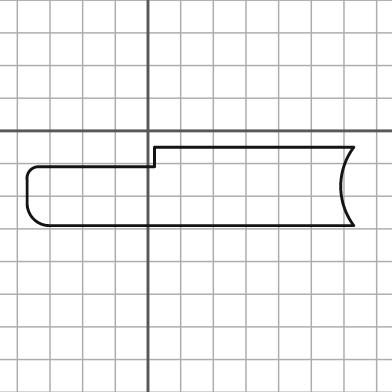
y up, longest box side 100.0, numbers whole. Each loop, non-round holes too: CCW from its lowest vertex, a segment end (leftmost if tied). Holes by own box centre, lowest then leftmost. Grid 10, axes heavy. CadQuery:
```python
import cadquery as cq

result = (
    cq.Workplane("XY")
    .moveTo(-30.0, -29.0)
    .lineTo(63.0, -29.0)
    .threePointArc((59.0, -17.0), (63.0, -5.0))
    .lineTo(2.0, -5.0)
    .lineTo(2.0, -11.0)
    .lineTo(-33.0, -11.0)
    .threePointArc((-36.0, -12.0), (-37.0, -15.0))
    .lineTo(-37.0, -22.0)
    .threePointArc((-35.0, -27.0), (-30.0, -29.0))
    .close()
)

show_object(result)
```